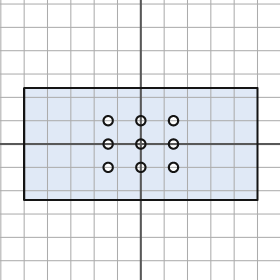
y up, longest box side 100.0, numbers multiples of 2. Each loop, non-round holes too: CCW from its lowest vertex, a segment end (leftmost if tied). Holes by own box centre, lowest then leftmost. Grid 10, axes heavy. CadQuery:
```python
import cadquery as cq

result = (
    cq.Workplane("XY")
    .moveTo(-50.0, -24.0)
    .lineTo(50.0, -24.0)
    .lineTo(50.0, 24.0)
    .lineTo(-50.0, 24.0)
    .close()
    .moveTo(-14.0, -10.0)
    .circle(2.0)
    .moveTo(0.0, -10.0)
    .circle(2.0)
    .moveTo(14.0, -10.0)
    .circle(2.0)
    .moveTo(-14.0, 0.0)
    .circle(2.0)
    .moveTo(0.0, 0.0)
    .circle(2.0)
    .moveTo(14.0, 0.0)
    .circle(2.0)
    .moveTo(-14.0, 10.0)
    .circle(2.0)
    .moveTo(0.0, 10.0)
    .circle(2.0)
    .moveTo(14.0, 10.0)
    .circle(2.0)
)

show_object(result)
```